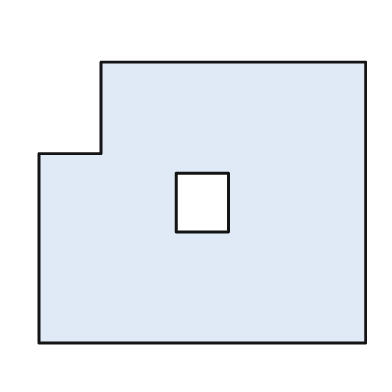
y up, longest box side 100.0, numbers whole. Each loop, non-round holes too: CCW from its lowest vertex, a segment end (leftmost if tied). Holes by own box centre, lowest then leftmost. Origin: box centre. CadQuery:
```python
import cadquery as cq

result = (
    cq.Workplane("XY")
    .moveTo(-50.0, -43.0)
    .lineTo(50.0, -43.0)
    .lineTo(50.0, 43.0)
    .lineTo(-31.0, 43.0)
    .lineTo(-31.0, 15.0)
    .lineTo(-50.0, 15.0)
    .close()
    .moveTo(-8.0, -9.0)
    .lineTo(8.0, -9.0)
    .lineTo(8.0, 9.0)
    .lineTo(-8.0, 9.0)
    .close()
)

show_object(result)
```